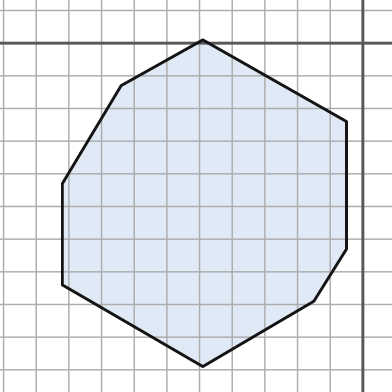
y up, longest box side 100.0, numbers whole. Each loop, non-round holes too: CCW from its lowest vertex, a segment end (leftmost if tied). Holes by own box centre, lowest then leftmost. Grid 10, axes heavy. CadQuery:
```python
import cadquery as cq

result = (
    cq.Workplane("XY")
    .moveTo(-49.0, -99.0)
    .lineTo(-15.0, -79.0)
    .lineTo(-5.0, -63.0)
    .lineTo(-5.0, -24.0)
    .lineTo(-49.0, 1.0)
    .lineTo(-74.0, -13.0)
    .lineTo(-92.0, -43.0)
    .lineTo(-92.0, -74.0)
    .close()
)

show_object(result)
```